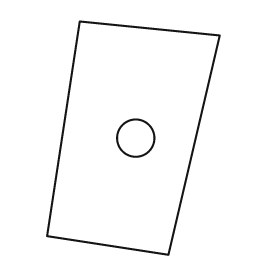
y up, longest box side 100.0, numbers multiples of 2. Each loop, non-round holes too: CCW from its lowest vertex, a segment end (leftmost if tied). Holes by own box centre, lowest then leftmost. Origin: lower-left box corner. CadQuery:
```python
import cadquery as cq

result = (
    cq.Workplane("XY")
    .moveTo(52.0, 0.0)
    .lineTo(74.0, 94.0)
    .lineTo(14.0, 100.0)
    .lineTo(0.0, 8.0)
    .close()
    .moveTo(38.0, 50.0)
    .circle(8.0)
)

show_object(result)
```